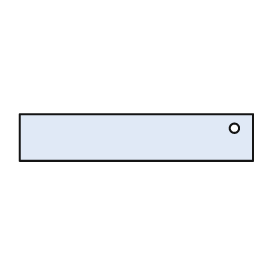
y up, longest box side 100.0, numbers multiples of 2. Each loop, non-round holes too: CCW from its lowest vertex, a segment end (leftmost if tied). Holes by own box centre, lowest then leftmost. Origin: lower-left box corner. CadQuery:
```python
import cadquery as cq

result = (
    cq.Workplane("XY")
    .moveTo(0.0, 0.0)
    .lineTo(100.0, 0.0)
    .lineTo(100.0, 20.0)
    .lineTo(0.0, 20.0)
    .close()
    .moveTo(92.0, 14.0)
    .circle(2.0)
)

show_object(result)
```